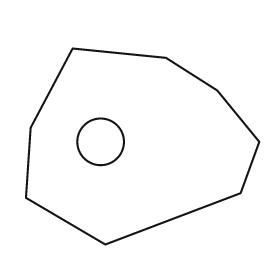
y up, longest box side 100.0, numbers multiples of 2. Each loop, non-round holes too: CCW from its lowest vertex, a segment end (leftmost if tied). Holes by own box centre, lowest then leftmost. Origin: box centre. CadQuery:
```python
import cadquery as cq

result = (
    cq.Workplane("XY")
    .moveTo(-16.0, -42.0)
    .lineTo(42.0, -20.0)
    .lineTo(50.0, 2.0)
    .lineTo(32.0, 24.0)
    .lineTo(10.0, 38.0)
    .lineTo(-30.0, 42.0)
    .lineTo(-48.0, 8.0)
    .lineTo(-50.0, -22.0)
    .close()
    .moveTo(-18.0, 2.0)
    .circle(10.0)
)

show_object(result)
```